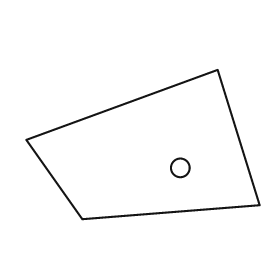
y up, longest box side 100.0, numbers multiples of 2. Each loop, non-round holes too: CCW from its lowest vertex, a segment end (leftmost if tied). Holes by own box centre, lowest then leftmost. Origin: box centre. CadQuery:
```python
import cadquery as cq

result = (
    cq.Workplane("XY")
    .moveTo(-26.0, -32.0)
    .lineTo(50.0, -26.0)
    .lineTo(32.0, 32.0)
    .lineTo(-50.0, 2.0)
    .close()
    .moveTo(16.0, -10.0)
    .circle(4.0)
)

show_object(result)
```